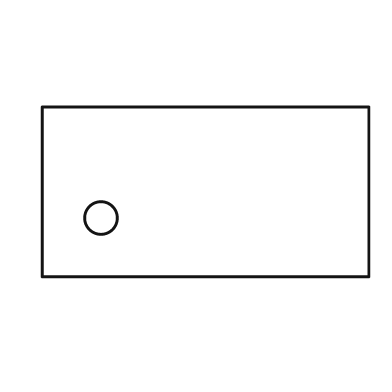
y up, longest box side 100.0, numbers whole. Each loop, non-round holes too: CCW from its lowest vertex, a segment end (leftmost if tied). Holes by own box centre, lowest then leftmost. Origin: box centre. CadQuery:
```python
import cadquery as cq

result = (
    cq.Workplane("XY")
    .moveTo(-50.0, -26.0)
    .lineTo(50.0, -26.0)
    .lineTo(50.0, 26.0)
    .lineTo(-50.0, 26.0)
    .close()
    .moveTo(-32.0, -8.0)
    .circle(5.0)
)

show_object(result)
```